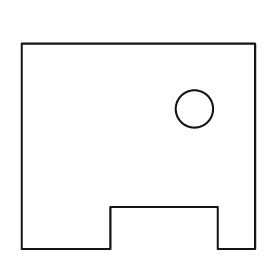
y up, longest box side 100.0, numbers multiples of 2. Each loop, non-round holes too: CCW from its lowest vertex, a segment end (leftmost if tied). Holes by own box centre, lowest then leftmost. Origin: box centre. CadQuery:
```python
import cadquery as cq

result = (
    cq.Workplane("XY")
    .moveTo(-50.0, -44.0)
    .lineTo(-12.0, -44.0)
    .lineTo(-12.0, -26.0)
    .lineTo(34.0, -26.0)
    .lineTo(34.0, -44.0)
    .lineTo(50.0, -44.0)
    .lineTo(50.0, 44.0)
    .lineTo(-50.0, 44.0)
    .close()
    .moveTo(24.0, 16.0)
    .circle(8.0)
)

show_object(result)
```